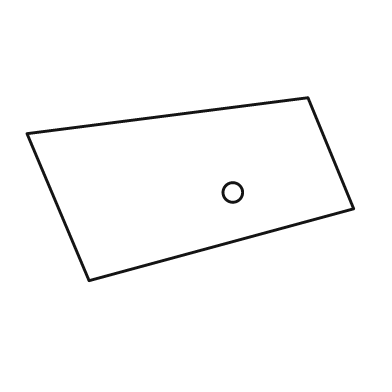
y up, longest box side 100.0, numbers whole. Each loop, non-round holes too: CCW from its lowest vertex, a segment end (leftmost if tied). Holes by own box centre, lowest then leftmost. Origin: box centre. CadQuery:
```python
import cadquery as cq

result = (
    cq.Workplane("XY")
    .moveTo(-31.0, -28.0)
    .lineTo(50.0, -6.0)
    .lineTo(36.0, 28.0)
    .lineTo(-50.0, 17.0)
    .close()
    .moveTo(13.0, -1.0)
    .circle(3.0)
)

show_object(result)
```